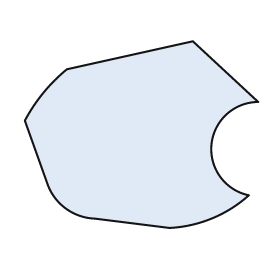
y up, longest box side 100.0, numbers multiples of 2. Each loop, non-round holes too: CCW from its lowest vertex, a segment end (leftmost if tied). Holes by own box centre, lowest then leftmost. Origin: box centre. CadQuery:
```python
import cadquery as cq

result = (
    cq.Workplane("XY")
    .moveTo(12.0, -40.0)
    .threePointArc((30.0, -36.0), (46.0, -26.0))
    .threePointArc((30.0, -4.0), (50.0, 14.0))
    .lineTo(22.0, 40.0)
    .lineTo(-32.0, 28.0)
    .threePointArc((-42.0, 18.0), (-50.0, 6.0))
    .lineTo(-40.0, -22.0)
    .threePointArc((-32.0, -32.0), (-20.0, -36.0))
    .close()
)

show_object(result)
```